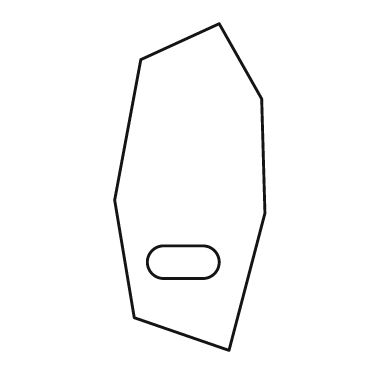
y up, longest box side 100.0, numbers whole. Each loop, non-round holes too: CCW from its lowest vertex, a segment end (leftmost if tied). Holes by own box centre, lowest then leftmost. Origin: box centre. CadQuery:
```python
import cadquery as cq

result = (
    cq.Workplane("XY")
    .moveTo(12.0, -50.0)
    .lineTo(23.0, -8.0)
    .lineTo(22.0, 27.0)
    .lineTo(9.0, 50.0)
    .lineTo(-15.0, 39.0)
    .lineTo(-23.0, -4.0)
    .lineTo(-17.0, -40.0)
    .close()
    .moveTo(-8.0, -28.0)
    .lineTo(4.0, -28.0)
    .threePointArc((9.0, -23.0), (4.0, -18.0))
    .lineTo(-8.0, -18.0)
    .threePointArc((-13.0, -23.0), (-8.0, -28.0))
    .close()
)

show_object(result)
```